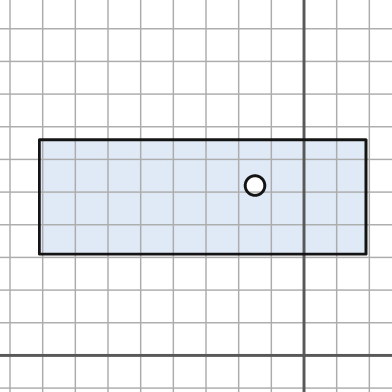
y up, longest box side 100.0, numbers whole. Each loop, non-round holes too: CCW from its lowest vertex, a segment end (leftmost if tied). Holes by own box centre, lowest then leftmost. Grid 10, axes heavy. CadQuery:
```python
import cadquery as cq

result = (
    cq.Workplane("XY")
    .moveTo(-81.0, 31.0)
    .lineTo(19.0, 31.0)
    .lineTo(19.0, 66.0)
    .lineTo(-81.0, 66.0)
    .close()
    .moveTo(-15.0, 52.0)
    .circle(3.0)
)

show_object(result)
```